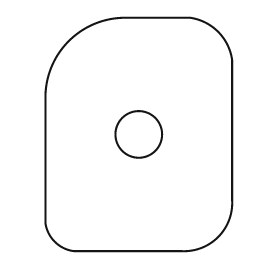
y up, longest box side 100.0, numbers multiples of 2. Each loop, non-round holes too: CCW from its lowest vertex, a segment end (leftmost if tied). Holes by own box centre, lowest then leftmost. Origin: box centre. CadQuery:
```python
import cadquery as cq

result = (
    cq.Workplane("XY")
    .moveTo(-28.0, -50.0)
    .lineTo(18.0, -50.0)
    .threePointArc((34.0, -44.0), (40.0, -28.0))
    .lineTo(40.0, 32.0)
    .threePointArc((34.0, 44.0), (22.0, 50.0))
    .lineTo(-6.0, 50.0)
    .threePointArc((-30.0, 40.0), (-40.0, 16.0))
    .lineTo(-40.0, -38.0)
    .threePointArc((-36.0, -46.0), (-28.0, -50.0))
    .close()
    .moveTo(0.0, 0.0)
    .circle(10.0)
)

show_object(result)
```